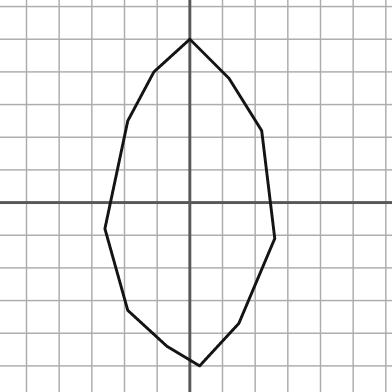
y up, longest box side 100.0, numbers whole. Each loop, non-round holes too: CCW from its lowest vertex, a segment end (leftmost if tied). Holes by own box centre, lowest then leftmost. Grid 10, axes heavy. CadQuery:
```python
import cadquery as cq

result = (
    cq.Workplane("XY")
    .moveTo(3.0, -50.0)
    .lineTo(15.0, -37.0)
    .lineTo(26.0, -11.0)
    .lineTo(22.0, 22.0)
    .lineTo(12.0, 38.0)
    .lineTo(0.0, 50.0)
    .lineTo(-11.0, 40.0)
    .lineTo(-19.0, 25.0)
    .lineTo(-26.0, -8.0)
    .lineTo(-19.0, -33.0)
    .lineTo(-7.0, -44.0)
    .close()
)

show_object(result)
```